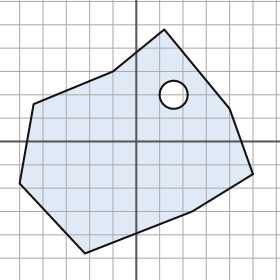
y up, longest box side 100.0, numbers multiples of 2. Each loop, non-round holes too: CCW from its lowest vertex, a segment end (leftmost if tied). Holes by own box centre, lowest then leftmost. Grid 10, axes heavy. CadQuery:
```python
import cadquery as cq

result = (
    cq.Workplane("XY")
    .moveTo(-22.0, -48.0)
    .lineTo(24.0, -30.0)
    .lineTo(50.0, -14.0)
    .lineTo(40.0, 14.0)
    .lineTo(12.0, 48.0)
    .lineTo(-10.0, 30.0)
    .lineTo(-44.0, 16.0)
    .lineTo(-50.0, -18.0)
    .close()
    .moveTo(16.0, 20.0)
    .circle(6.0)
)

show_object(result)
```